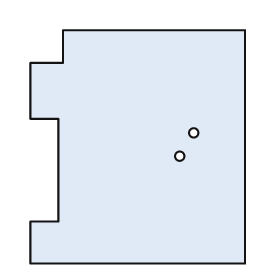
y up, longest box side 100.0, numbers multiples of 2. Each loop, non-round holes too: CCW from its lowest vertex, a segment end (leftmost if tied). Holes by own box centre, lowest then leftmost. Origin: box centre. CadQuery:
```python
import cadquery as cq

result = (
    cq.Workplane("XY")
    .moveTo(-46.0, -50.0)
    .lineTo(46.0, -50.0)
    .lineTo(46.0, 50.0)
    .lineTo(-32.0, 50.0)
    .lineTo(-32.0, 36.0)
    .lineTo(-46.0, 36.0)
    .lineTo(-46.0, 12.0)
    .lineTo(-34.0, 12.0)
    .lineTo(-34.0, -32.0)
    .lineTo(-46.0, -32.0)
    .close()
    .moveTo(18.0, -4.0)
    .circle(2.0)
    .moveTo(24.0, 6.0)
    .circle(2.0)
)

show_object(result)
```